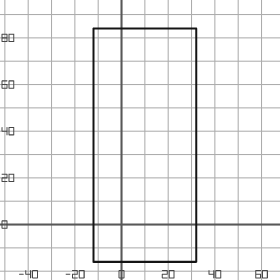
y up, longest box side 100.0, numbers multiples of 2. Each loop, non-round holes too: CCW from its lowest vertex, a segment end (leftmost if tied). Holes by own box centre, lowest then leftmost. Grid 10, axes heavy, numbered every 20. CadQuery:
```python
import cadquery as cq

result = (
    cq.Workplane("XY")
    .moveTo(-12.0, -16.0)
    .lineTo(32.0, -16.0)
    .lineTo(32.0, 84.0)
    .lineTo(-12.0, 84.0)
    .close()
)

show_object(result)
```